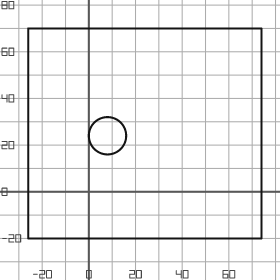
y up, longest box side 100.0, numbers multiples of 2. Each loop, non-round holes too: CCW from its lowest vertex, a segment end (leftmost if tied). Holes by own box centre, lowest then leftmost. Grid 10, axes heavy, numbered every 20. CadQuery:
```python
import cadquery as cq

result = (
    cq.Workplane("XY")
    .moveTo(-26.0, -20.0)
    .lineTo(74.0, -20.0)
    .lineTo(74.0, 70.0)
    .lineTo(-26.0, 70.0)
    .close()
    .moveTo(8.0, 24.0)
    .circle(8.0)
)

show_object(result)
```